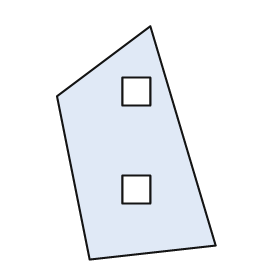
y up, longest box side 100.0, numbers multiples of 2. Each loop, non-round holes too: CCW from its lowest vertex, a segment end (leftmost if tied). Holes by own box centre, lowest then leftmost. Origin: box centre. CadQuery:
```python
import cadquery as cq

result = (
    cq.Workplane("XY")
    .moveTo(-20.0, -50.0)
    .lineTo(34.0, -44.0)
    .lineTo(6.0, 50.0)
    .lineTo(-34.0, 20.0)
    .close()
    .moveTo(-6.0, -26.0)
    .lineTo(6.0, -26.0)
    .lineTo(6.0, -14.0)
    .lineTo(-6.0, -14.0)
    .close()
    .moveTo(-6.0, 16.0)
    .lineTo(6.0, 16.0)
    .lineTo(6.0, 28.0)
    .lineTo(-6.0, 28.0)
    .close()
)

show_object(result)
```